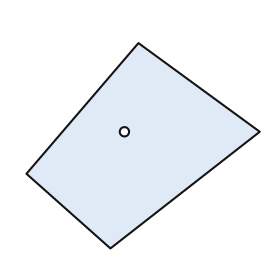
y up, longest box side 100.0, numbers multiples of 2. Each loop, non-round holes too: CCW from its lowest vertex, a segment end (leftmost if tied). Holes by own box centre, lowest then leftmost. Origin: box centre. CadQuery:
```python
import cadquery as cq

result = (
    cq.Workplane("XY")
    .moveTo(-14.0, -44.0)
    .lineTo(50.0, 6.0)
    .lineTo(-2.0, 44.0)
    .lineTo(-50.0, -12.0)
    .close()
    .moveTo(-8.0, 6.0)
    .circle(2.0)
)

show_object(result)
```